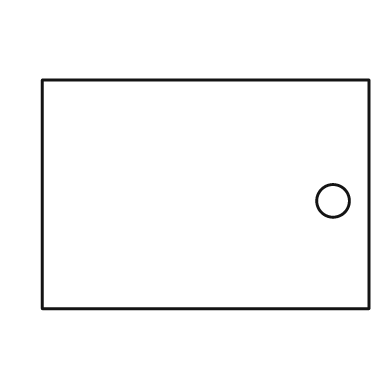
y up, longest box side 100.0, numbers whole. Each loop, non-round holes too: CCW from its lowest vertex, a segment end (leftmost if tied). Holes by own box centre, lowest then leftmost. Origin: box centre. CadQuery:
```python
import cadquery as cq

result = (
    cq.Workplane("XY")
    .moveTo(-50.0, -35.0)
    .lineTo(50.0, -35.0)
    .lineTo(50.0, 35.0)
    .lineTo(-50.0, 35.0)
    .close()
    .moveTo(39.0, -2.0)
    .circle(5.0)
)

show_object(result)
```